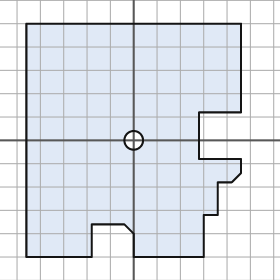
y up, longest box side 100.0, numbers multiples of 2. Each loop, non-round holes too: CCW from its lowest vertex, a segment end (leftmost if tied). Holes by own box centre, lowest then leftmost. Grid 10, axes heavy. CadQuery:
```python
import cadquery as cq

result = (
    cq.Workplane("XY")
    .moveTo(-46.0, -50.0)
    .lineTo(-18.0, -50.0)
    .lineTo(-18.0, -36.0)
    .lineTo(-4.0, -36.0)
    .lineTo(0.0, -40.0)
    .lineTo(0.0, -50.0)
    .lineTo(30.0, -50.0)
    .lineTo(30.0, -32.0)
    .lineTo(36.0, -32.0)
    .lineTo(36.0, -18.0)
    .lineTo(42.0, -18.0)
    .lineTo(46.0, -14.0)
    .lineTo(46.0, -8.0)
    .lineTo(28.0, -8.0)
    .lineTo(28.0, 12.0)
    .lineTo(46.0, 12.0)
    .lineTo(46.0, 50.0)
    .lineTo(-46.0, 50.0)
    .close()
    .moveTo(0.0, 0.0)
    .circle(4.0)
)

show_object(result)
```